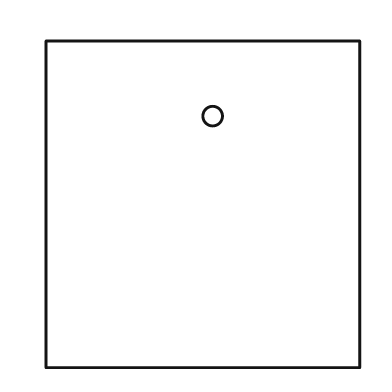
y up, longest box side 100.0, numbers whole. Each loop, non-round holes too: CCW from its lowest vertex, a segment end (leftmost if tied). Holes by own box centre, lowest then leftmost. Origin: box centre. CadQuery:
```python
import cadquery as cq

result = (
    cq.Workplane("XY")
    .moveTo(-48.0, -50.0)
    .lineTo(48.0, -50.0)
    .lineTo(48.0, 50.0)
    .lineTo(-48.0, 50.0)
    .close()
    .moveTo(3.0, 27.0)
    .circle(3.0)
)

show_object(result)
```